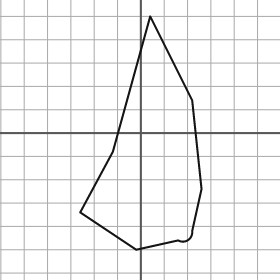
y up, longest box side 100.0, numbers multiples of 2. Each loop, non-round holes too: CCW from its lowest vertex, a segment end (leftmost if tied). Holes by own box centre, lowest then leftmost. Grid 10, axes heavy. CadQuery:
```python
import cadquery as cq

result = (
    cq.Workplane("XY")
    .moveTo(-2.0, -50.0)
    .lineTo(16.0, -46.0)
    .threePointArc((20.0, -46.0), (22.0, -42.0))
    .lineTo(26.0, -24.0)
    .lineTo(22.0, 14.0)
    .lineTo(4.0, 50.0)
    .lineTo(-12.0, -8.0)
    .lineTo(-26.0, -34.0)
    .close()
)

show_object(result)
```